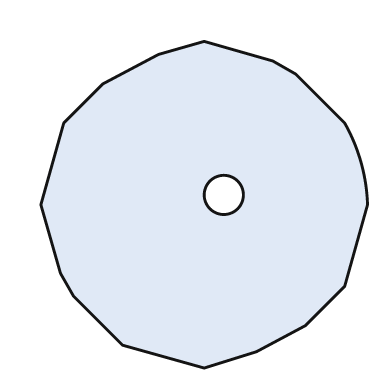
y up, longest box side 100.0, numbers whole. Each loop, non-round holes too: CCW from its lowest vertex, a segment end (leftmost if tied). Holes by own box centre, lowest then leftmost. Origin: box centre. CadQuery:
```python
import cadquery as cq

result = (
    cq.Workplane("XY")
    .moveTo(0.0, -50.0)
    .lineTo(16.0, -45.0)
    .lineTo(31.0, -37.0)
    .lineTo(43.0, -25.0)
    .lineTo(50.0, 0.0)
    .threePointArc((48.0, 13.0), (43.0, 25.0))
    .lineTo(28.0, 40.0)
    .lineTo(21.0, 44.0)
    .lineTo(0.0, 50.0)
    .lineTo(-14.0, 46.0)
    .lineTo(-31.0, 37.0)
    .lineTo(-43.0, 25.0)
    .lineTo(-50.0, 0.0)
    .lineTo(-44.0, -21.0)
    .lineTo(-40.0, -28.0)
    .lineTo(-25.0, -43.0)
    .close()
    .moveTo(6.0, 3.0)
    .circle(6.0)
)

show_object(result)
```